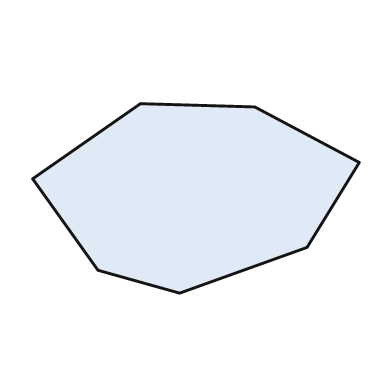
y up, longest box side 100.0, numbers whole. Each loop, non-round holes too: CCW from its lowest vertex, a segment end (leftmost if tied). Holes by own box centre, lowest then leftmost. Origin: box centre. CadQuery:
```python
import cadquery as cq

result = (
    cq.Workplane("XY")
    .moveTo(-5.0, -29.0)
    .lineTo(34.0, -15.0)
    .lineTo(50.0, 11.0)
    .lineTo(18.0, 28.0)
    .lineTo(-17.0, 29.0)
    .lineTo(-50.0, 6.0)
    .lineTo(-30.0, -22.0)
    .close()
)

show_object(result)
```